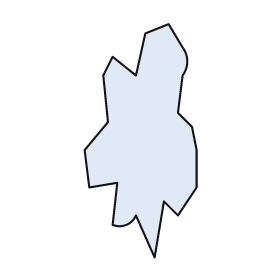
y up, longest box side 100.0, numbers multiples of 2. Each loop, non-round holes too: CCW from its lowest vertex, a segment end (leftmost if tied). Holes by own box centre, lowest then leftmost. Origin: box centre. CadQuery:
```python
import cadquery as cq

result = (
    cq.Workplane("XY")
    .moveTo(6.0, -50.0)
    .lineTo(10.0, -26.0)
    .lineTo(16.0, -32.0)
    .lineTo(24.0, -20.0)
    .lineTo(24.0, -4.0)
    .lineTo(22.0, 6.0)
    .lineTo(16.0, 12.0)
    .lineTo(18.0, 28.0)
    .threePointArc((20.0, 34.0), (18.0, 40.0))
    .lineTo(12.0, 50.0)
    .lineTo(2.0, 46.0)
    .lineTo(-2.0, 28.0)
    .lineTo(-12.0, 36.0)
    .lineTo(-16.0, 28.0)
    .lineTo(-14.0, 8.0)
    .lineTo(-24.0, -4.0)
    .lineTo(-22.0, -20.0)
    .lineTo(-10.0, -18.0)
    .lineTo(-12.0, -36.0)
    .threePointArc((-6.0, -36.0), (-2.0, -32.0))
    .close()
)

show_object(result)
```